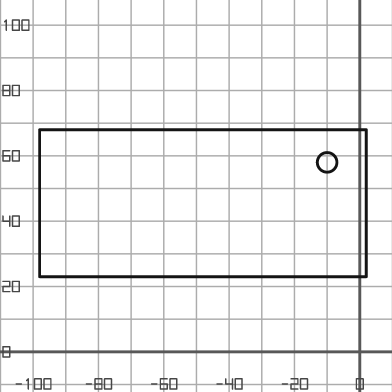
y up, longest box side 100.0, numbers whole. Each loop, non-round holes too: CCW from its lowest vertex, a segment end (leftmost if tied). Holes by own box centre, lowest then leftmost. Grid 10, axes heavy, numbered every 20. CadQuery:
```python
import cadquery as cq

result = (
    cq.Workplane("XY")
    .moveTo(-98.0, 23.0)
    .lineTo(2.0, 23.0)
    .lineTo(2.0, 68.0)
    .lineTo(-98.0, 68.0)
    .close()
    .moveTo(-10.0, 58.0)
    .circle(3.0)
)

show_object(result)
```